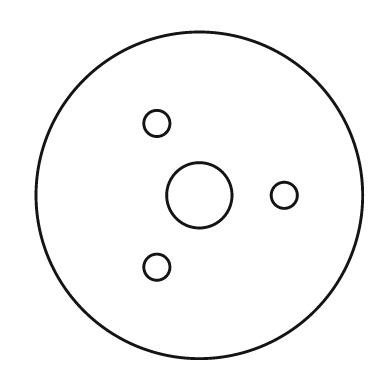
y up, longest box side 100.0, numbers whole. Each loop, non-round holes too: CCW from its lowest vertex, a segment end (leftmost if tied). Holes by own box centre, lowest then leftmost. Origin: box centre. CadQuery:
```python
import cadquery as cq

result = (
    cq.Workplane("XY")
    .moveTo(0.0, 0.0)
    .circle(50.0)
    .moveTo(-13.0, -22.0)
    .circle(4.0)
    .moveTo(0.0, 0.0)
    .circle(10.0)
    .moveTo(26.0, 0.0)
    .circle(4.0)
    .moveTo(-13.0, 22.0)
    .circle(4.0)
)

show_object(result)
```